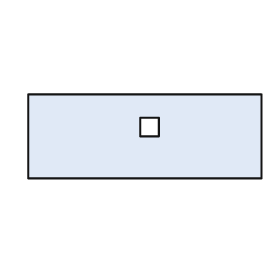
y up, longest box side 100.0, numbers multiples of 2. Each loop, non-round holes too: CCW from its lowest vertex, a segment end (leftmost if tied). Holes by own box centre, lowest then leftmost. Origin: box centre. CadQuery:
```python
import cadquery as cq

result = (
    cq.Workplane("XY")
    .moveTo(-50.0, -18.0)
    .lineTo(50.0, -18.0)
    .lineTo(50.0, 18.0)
    .lineTo(-50.0, 18.0)
    .close()
    .moveTo(-2.0, 0.0)
    .lineTo(6.0, 0.0)
    .lineTo(6.0, 8.0)
    .lineTo(-2.0, 8.0)
    .close()
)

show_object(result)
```